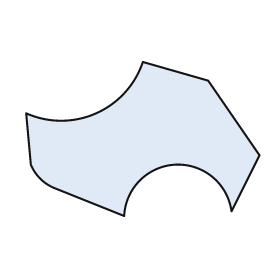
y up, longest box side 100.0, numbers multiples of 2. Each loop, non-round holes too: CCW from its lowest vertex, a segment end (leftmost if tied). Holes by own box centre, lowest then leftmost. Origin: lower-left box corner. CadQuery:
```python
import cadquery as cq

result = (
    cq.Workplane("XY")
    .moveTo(42.0, 0.0)
    .threePointArc((64.0, 22.0), (88.0, 2.0))
    .lineTo(100.0, 26.0)
    .lineTo(78.0, 58.0)
    .lineTo(50.0, 66.0)
    .threePointArc((30.0, 44.0), (0.0, 44.0))
    .lineTo(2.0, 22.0)
    .threePointArc((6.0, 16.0), (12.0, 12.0))
    .close()
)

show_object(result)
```